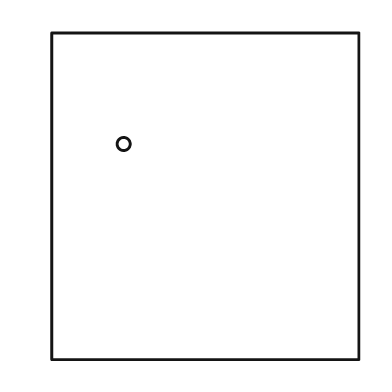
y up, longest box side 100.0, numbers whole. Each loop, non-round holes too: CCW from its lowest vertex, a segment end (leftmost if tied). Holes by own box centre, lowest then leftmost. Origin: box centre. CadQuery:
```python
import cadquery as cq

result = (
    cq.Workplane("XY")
    .moveTo(-47.0, -50.0)
    .lineTo(47.0, -50.0)
    .lineTo(47.0, 50.0)
    .lineTo(-47.0, 50.0)
    .close()
    .moveTo(-25.0, 16.0)
    .circle(2.0)
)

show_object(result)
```